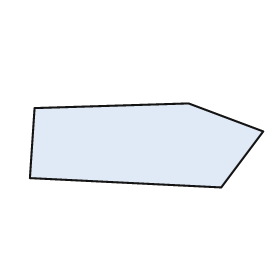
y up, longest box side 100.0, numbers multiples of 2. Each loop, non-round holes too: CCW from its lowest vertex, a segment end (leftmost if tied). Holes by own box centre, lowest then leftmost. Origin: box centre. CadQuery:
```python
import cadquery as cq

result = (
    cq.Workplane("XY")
    .moveTo(32.0, -18.0)
    .lineTo(50.0, 6.0)
    .lineTo(18.0, 18.0)
    .lineTo(-48.0, 16.0)
    .lineTo(-50.0, -14.0)
    .close()
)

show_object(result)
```